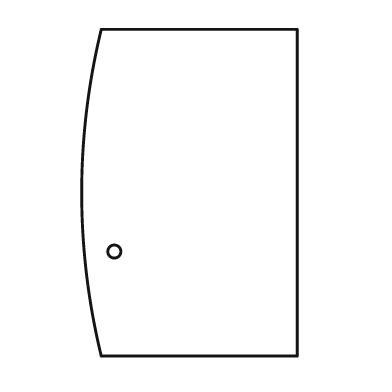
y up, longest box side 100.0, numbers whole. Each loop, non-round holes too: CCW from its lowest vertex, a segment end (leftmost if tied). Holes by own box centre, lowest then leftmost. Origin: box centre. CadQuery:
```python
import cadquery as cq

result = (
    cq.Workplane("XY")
    .moveTo(-27.0, -50.0)
    .lineTo(33.0, -50.0)
    .lineTo(33.0, 50.0)
    .lineTo(-27.0, 50.0)
    .threePointArc((-33.0, 0.0), (-27.0, -50.0))
    .close()
    .moveTo(-23.0, -18.0)
    .circle(2.0)
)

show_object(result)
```